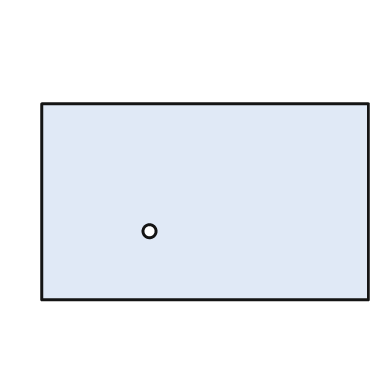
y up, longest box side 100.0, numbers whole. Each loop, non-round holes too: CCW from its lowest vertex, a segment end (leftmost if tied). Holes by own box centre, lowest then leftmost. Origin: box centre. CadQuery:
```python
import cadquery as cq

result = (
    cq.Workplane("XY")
    .moveTo(-50.0, -30.0)
    .lineTo(50.0, -30.0)
    .lineTo(50.0, 30.0)
    .lineTo(-50.0, 30.0)
    .close()
    .moveTo(-17.0, -9.0)
    .circle(2.0)
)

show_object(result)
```